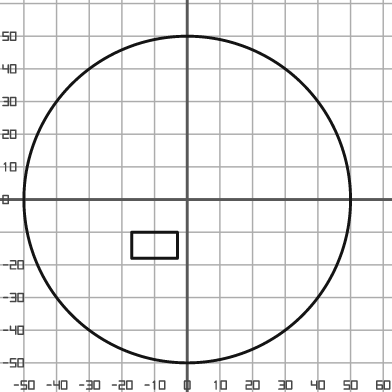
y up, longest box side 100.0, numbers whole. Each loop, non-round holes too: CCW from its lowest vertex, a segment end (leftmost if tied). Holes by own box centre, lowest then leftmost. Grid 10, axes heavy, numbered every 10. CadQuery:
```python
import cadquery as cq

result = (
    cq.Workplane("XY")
    .moveTo(0.0, 0.0)
    .circle(50.0)
    .moveTo(-17.0, -18.0)
    .lineTo(-3.0, -18.0)
    .lineTo(-3.0, -10.0)
    .lineTo(-17.0, -10.0)
    .close()
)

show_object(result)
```